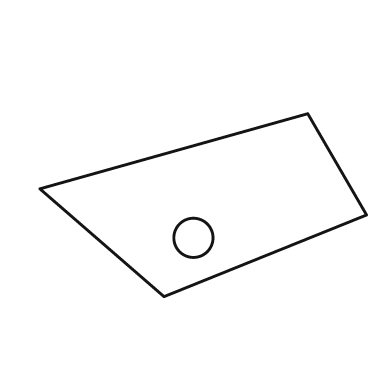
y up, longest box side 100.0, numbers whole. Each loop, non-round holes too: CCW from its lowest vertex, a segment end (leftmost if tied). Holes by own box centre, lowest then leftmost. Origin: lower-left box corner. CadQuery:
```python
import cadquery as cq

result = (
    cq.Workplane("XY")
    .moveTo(38.0, 0.0)
    .lineTo(100.0, 25.0)
    .lineTo(82.0, 56.0)
    .lineTo(0.0, 33.0)
    .close()
    .moveTo(47.0, 18.0)
    .circle(6.0)
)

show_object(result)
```